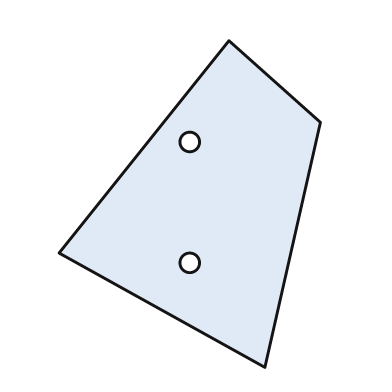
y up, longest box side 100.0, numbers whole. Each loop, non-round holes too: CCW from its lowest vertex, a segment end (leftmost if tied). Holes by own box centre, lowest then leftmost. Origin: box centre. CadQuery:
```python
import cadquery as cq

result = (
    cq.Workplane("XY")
    .moveTo(23.0, -50.0)
    .lineTo(40.0, 25.0)
    .lineTo(12.0, 50.0)
    .lineTo(-40.0, -15.0)
    .close()
    .moveTo(0.0, -18.0)
    .circle(3.0)
    .moveTo(0.0, 19.0)
    .circle(3.0)
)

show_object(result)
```